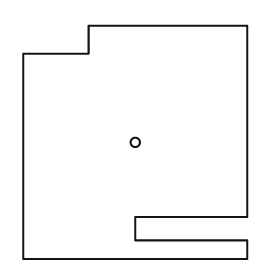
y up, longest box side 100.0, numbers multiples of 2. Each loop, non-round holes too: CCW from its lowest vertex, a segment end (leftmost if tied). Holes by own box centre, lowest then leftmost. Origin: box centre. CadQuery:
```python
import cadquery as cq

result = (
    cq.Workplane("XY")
    .moveTo(-48.0, -50.0)
    .lineTo(48.0, -50.0)
    .lineTo(48.0, -42.0)
    .lineTo(0.0, -42.0)
    .lineTo(0.0, -32.0)
    .lineTo(48.0, -32.0)
    .lineTo(48.0, 50.0)
    .lineTo(-20.0, 50.0)
    .lineTo(-20.0, 38.0)
    .lineTo(-48.0, 38.0)
    .close()
    .moveTo(0.0, 0.0)
    .circle(2.0)
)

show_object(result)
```